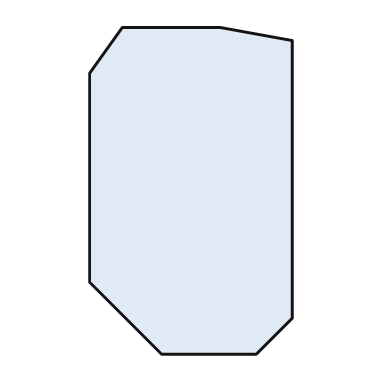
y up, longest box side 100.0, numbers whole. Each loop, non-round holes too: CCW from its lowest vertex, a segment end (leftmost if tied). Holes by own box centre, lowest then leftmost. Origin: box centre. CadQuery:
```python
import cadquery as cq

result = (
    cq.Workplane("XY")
    .moveTo(-9.0, -50.0)
    .lineTo(20.0, -50.0)
    .lineTo(31.0, -39.0)
    .lineTo(31.0, 46.0)
    .lineTo(9.0, 50.0)
    .lineTo(-21.0, 50.0)
    .lineTo(-31.0, 36.0)
    .lineTo(-31.0, -28.0)
    .close()
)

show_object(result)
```